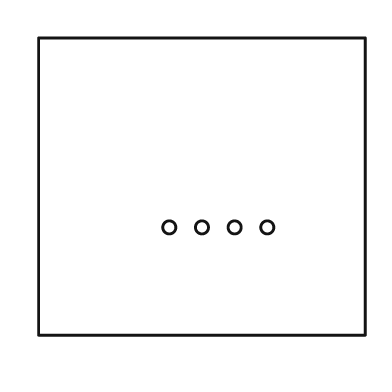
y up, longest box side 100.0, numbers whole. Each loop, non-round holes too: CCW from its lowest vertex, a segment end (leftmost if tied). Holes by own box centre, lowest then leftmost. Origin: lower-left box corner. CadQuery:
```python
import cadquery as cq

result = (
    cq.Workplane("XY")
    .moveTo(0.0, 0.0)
    .lineTo(100.0, 0.0)
    .lineTo(100.0, 91.0)
    .lineTo(0.0, 91.0)
    .close()
    .moveTo(40.0, 33.0)
    .circle(2.0)
    .moveTo(50.0, 33.0)
    .circle(2.0)
    .moveTo(60.0, 33.0)
    .circle(2.0)
    .moveTo(70.0, 33.0)
    .circle(2.0)
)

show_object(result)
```